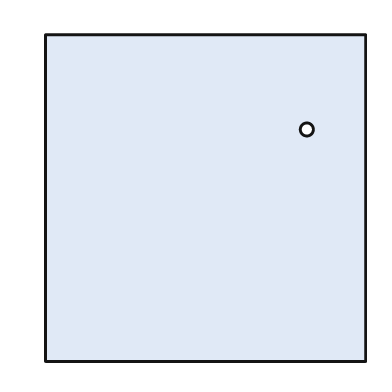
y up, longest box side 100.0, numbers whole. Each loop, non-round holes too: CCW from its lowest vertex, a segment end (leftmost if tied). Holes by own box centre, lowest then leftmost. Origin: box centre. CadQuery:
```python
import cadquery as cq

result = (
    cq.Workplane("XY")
    .moveTo(-49.0, -50.0)
    .lineTo(49.0, -50.0)
    .lineTo(49.0, 50.0)
    .lineTo(-49.0, 50.0)
    .close()
    .moveTo(31.0, 21.0)
    .circle(2.0)
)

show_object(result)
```